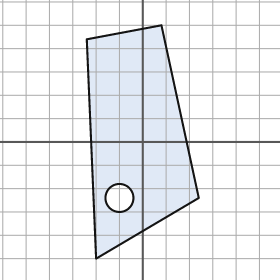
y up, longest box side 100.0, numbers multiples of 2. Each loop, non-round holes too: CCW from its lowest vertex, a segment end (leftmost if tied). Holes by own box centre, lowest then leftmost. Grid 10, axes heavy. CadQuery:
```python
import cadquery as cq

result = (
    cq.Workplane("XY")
    .moveTo(-20.0, -50.0)
    .lineTo(24.0, -24.0)
    .lineTo(8.0, 50.0)
    .lineTo(-24.0, 44.0)
    .close()
    .moveTo(-10.0, -24.0)
    .circle(6.0)
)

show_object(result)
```